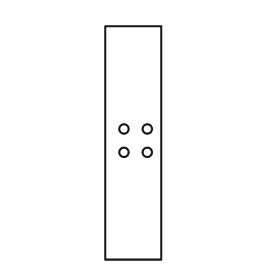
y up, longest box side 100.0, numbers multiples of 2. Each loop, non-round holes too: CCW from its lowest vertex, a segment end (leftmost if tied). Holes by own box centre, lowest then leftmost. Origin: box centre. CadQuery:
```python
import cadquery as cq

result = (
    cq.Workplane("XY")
    .moveTo(-12.0, -50.0)
    .lineTo(12.0, -50.0)
    .lineTo(12.0, 50.0)
    .lineTo(-12.0, 50.0)
    .close()
    .moveTo(-4.0, -4.0)
    .circle(2.0)
    .moveTo(6.0, -4.0)
    .circle(2.0)
    .moveTo(-4.0, 6.0)
    .circle(2.0)
    .moveTo(6.0, 6.0)
    .circle(2.0)
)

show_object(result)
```